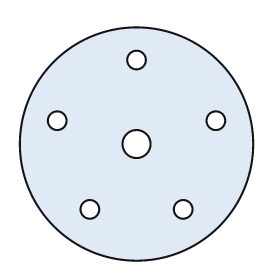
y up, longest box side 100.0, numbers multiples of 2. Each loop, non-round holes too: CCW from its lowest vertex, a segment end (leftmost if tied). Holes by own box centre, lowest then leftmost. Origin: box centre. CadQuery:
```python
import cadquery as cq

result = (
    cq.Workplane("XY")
    .moveTo(0.0, 0.0)
    .circle(50.0)
    .moveTo(-20.0, -28.0)
    .circle(4.0)
    .moveTo(20.0, -28.0)
    .circle(4.0)
    .moveTo(0.0, 0.0)
    .circle(6.0)
    .moveTo(-34.0, 10.0)
    .circle(4.0)
    .moveTo(34.0, 10.0)
    .circle(4.0)
    .moveTo(0.0, 36.0)
    .circle(4.0)
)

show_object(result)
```